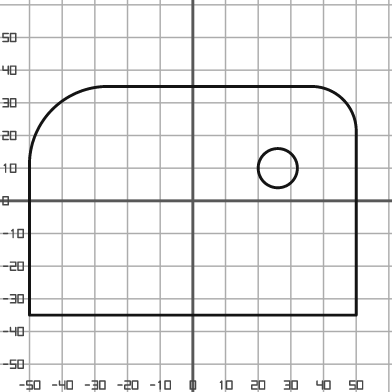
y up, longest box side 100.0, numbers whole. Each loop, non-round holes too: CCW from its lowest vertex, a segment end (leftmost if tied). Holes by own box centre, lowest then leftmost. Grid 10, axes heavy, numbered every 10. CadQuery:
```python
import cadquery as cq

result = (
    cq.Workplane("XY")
    .moveTo(-50.0, -35.0)
    .lineTo(50.0, -35.0)
    .lineTo(50.0, 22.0)
    .threePointArc((46.0, 31.0), (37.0, 35.0))
    .lineTo(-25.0, 35.0)
    .threePointArc((-43.0, 28.0), (-50.0, 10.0))
    .close()
    .moveTo(26.0, 10.0)
    .circle(6.0)
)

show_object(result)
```